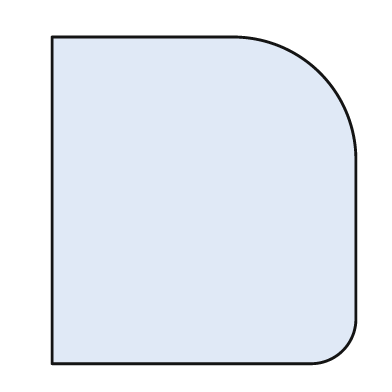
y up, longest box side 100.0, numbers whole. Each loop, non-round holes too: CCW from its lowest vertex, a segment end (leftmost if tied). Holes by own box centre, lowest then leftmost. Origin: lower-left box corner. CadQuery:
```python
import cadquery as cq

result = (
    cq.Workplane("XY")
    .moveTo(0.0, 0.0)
    .lineTo(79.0, 0.0)
    .threePointArc((89.0, 4.0), (93.0, 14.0))
    .lineTo(93.0, 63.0)
    .threePointArc((82.0, 89.0), (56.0, 100.0))
    .lineTo(0.0, 100.0)
    .close()
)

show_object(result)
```